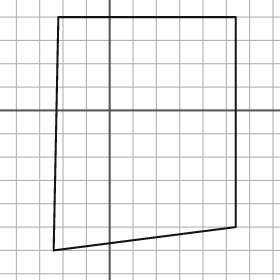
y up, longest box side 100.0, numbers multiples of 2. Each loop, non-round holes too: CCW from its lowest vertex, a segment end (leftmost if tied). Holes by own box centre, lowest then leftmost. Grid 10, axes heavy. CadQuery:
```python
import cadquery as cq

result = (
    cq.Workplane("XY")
    .moveTo(-24.0, -60.0)
    .lineTo(54.0, -50.0)
    .lineTo(54.0, 40.0)
    .lineTo(-22.0, 40.0)
    .close()
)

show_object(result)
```